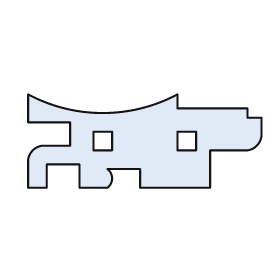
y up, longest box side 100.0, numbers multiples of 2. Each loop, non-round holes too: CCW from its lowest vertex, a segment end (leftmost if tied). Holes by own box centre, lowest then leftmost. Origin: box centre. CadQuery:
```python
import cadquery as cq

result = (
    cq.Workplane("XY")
    .moveTo(-50.0, -20.0)
    .lineTo(-42.0, -20.0)
    .lineTo(-42.0, -10.0)
    .lineTo(-28.0, -10.0)
    .lineTo(-28.0, -20.0)
    .lineTo(-16.0, -20.0)
    .threePointArc((-14.0, -16.0), (-16.0, -12.0))
    .lineTo(-2.0, -12.0)
    .lineTo(-2.0, -20.0)
    .lineTo(28.0, -20.0)
    .lineTo(28.0, -4.0)
    .lineTo(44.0, -4.0)
    .threePointArc((48.0, -2.0), (50.0, 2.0))
    .lineTo(50.0, 10.0)
    .lineTo(44.0, 10.0)
    .lineTo(44.0, 14.0)
    .lineTo(14.0, 14.0)
    .lineTo(14.0, 20.0)
    .threePointArc((-18.0, 12.0), (-50.0, 20.0))
    .lineTo(-50.0, 8.0)
    .lineTo(-32.0, 8.0)
    .lineTo(-32.0, -2.0)
    .lineTo(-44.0, -2.0)
    .threePointArc((-48.0, -4.0), (-50.0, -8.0))
    .close()
    .moveTo(-22.0, -4.0)
    .lineTo(-14.0, -4.0)
    .lineTo(-14.0, 4.0)
    .lineTo(-22.0, 4.0)
    .close()
    .moveTo(14.0, -4.0)
    .lineTo(22.0, -4.0)
    .lineTo(22.0, 4.0)
    .lineTo(14.0, 4.0)
    .close()
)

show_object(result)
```